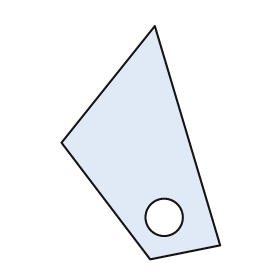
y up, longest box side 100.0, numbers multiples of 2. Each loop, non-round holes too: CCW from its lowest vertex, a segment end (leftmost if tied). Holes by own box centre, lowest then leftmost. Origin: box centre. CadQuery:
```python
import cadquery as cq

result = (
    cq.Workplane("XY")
    .moveTo(4.0, -50.0)
    .lineTo(34.0, -44.0)
    .lineTo(6.0, 50.0)
    .lineTo(-34.0, 0.0)
    .close()
    .moveTo(10.0, -32.0)
    .circle(8.0)
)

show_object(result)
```